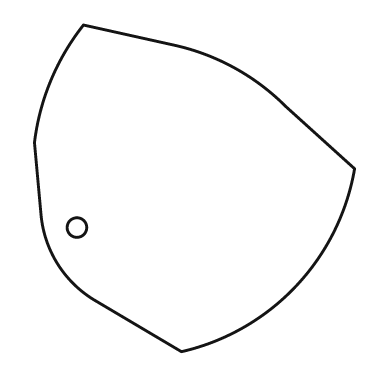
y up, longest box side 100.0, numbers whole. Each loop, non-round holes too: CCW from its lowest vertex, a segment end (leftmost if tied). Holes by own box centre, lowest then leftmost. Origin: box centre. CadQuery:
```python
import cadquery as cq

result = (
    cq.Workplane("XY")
    .moveTo(-4.0, -50.0)
    .threePointArc((31.0, -30.0), (49.0, 6.0))
    .lineTo(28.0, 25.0)
    .threePointArc((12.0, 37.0), (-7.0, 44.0))
    .lineTo(-34.0, 50.0)
    .threePointArc((-44.0, 33.0), (-49.0, 14.0))
    .lineTo(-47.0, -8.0)
    .threePointArc((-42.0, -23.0), (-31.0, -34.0))
    .close()
    .moveTo(-36.0, -12.0)
    .circle(3.0)
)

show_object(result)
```